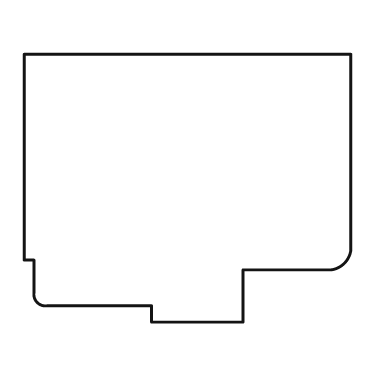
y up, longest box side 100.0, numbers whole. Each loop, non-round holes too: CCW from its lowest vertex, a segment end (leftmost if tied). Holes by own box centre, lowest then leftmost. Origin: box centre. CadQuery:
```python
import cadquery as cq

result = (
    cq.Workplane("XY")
    .moveTo(-11.0, -41.0)
    .lineTo(17.0, -41.0)
    .lineTo(17.0, -25.0)
    .lineTo(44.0, -25.0)
    .threePointArc((48.0, -23.0), (50.0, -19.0))
    .lineTo(50.0, 41.0)
    .lineTo(-50.0, 41.0)
    .lineTo(-50.0, -22.0)
    .lineTo(-47.0, -22.0)
    .lineTo(-47.0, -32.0)
    .threePointArc((-46.0, -35.0), (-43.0, -36.0))
    .lineTo(-11.0, -36.0)
    .close()
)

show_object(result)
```